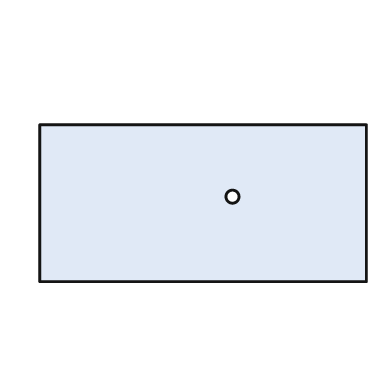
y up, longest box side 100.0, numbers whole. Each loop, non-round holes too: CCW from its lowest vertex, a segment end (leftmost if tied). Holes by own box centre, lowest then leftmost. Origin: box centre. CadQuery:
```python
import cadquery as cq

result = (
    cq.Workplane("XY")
    .moveTo(-50.0, -24.0)
    .lineTo(50.0, -24.0)
    .lineTo(50.0, 24.0)
    .lineTo(-50.0, 24.0)
    .close()
    .moveTo(9.0, 2.0)
    .circle(2.0)
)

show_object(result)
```